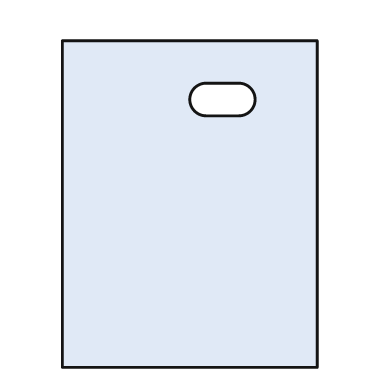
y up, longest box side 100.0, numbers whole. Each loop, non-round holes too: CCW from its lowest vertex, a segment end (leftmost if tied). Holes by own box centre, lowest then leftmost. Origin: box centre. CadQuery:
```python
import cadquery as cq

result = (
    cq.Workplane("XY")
    .moveTo(-39.0, -50.0)
    .lineTo(39.0, -50.0)
    .lineTo(39.0, 50.0)
    .lineTo(-39.0, 50.0)
    .close()
    .moveTo(5.0, 27.0)
    .lineTo(15.0, 27.0)
    .threePointArc((20.0, 32.0), (15.0, 37.0))
    .lineTo(5.0, 37.0)
    .threePointArc((0.0, 32.0), (5.0, 27.0))
    .close()
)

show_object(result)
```